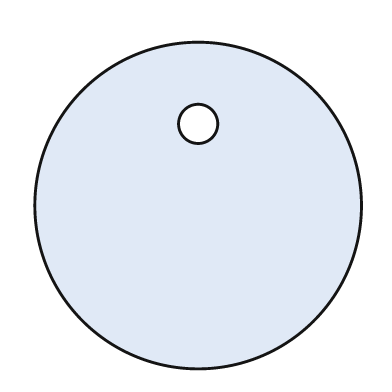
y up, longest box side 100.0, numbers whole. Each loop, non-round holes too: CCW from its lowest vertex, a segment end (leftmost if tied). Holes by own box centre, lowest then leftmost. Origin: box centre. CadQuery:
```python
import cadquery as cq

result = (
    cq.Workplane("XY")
    .moveTo(0.0, 0.0)
    .circle(50.0)
    .moveTo(0.0, 25.0)
    .circle(6.0)
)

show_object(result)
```